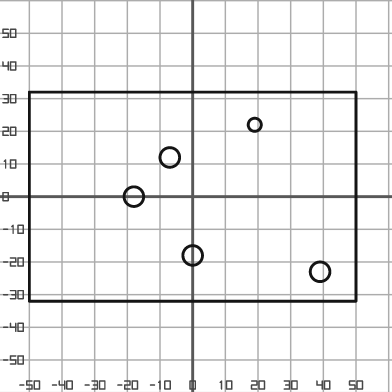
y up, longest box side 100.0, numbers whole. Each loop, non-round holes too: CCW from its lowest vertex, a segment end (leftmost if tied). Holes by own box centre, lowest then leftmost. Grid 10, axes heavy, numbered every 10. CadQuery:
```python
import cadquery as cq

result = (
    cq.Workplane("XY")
    .moveTo(-50.0, -32.0)
    .lineTo(50.0, -32.0)
    .lineTo(50.0, 32.0)
    .lineTo(-50.0, 32.0)
    .close()
    .moveTo(39.0, -23.0)
    .circle(3.0)
    .moveTo(0.0, -18.0)
    .circle(3.0)
    .moveTo(-18.0, 0.0)
    .circle(3.0)
    .moveTo(-7.0, 12.0)
    .circle(3.0)
    .moveTo(19.0, 22.0)
    .circle(2.0)
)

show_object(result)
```